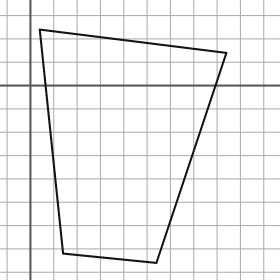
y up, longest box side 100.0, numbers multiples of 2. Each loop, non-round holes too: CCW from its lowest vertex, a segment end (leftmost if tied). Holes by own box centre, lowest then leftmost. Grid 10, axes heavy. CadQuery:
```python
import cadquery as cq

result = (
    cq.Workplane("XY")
    .moveTo(54.0, -76.0)
    .lineTo(84.0, 14.0)
    .lineTo(4.0, 24.0)
    .lineTo(14.0, -72.0)
    .close()
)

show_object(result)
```